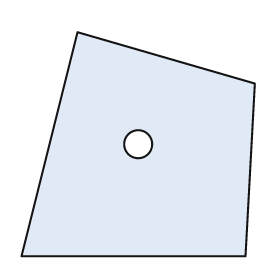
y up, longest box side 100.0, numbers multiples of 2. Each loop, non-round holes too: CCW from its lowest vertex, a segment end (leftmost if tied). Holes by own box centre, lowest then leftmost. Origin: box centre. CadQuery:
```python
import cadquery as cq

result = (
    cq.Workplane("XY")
    .moveTo(-50.0, -48.0)
    .lineTo(46.0, -48.0)
    .lineTo(50.0, 26.0)
    .lineTo(-26.0, 48.0)
    .close()
    .moveTo(0.0, 0.0)
    .circle(6.0)
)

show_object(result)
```